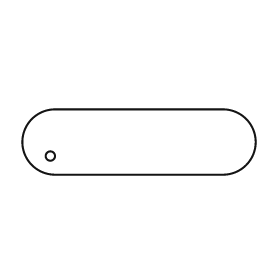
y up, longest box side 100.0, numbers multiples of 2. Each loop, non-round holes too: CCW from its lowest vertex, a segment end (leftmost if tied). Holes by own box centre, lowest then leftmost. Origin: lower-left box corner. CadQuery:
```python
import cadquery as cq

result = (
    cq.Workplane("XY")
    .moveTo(14.0, 0.0)
    .lineTo(86.0, 0.0)
    .threePointArc((100.0, 14.0), (86.0, 28.0))
    .lineTo(14.0, 28.0)
    .threePointArc((0.0, 14.0), (14.0, 0.0))
    .close()
    .moveTo(12.0, 8.0)
    .circle(2.0)
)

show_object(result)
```